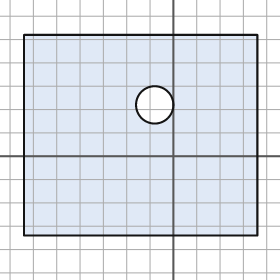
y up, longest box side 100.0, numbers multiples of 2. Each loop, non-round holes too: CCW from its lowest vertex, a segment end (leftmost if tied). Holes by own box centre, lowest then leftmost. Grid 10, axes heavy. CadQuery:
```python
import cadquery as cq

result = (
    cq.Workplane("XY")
    .moveTo(-64.0, -34.0)
    .lineTo(36.0, -34.0)
    .lineTo(36.0, 52.0)
    .lineTo(-64.0, 52.0)
    .close()
    .moveTo(-8.0, 22.0)
    .circle(8.0)
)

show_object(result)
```